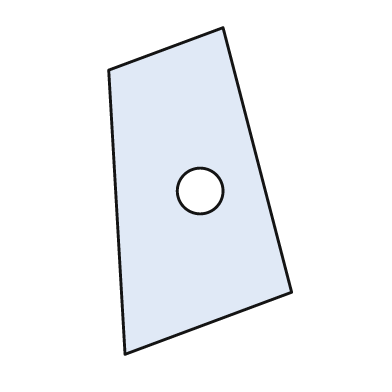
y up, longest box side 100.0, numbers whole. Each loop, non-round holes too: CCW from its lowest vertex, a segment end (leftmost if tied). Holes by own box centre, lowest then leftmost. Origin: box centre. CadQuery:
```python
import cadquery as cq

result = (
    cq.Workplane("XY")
    .moveTo(-23.0, -50.0)
    .lineTo(28.0, -31.0)
    .lineTo(7.0, 50.0)
    .lineTo(-28.0, 37.0)
    .close()
    .moveTo(0.0, 0.0)
    .circle(7.0)
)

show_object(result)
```